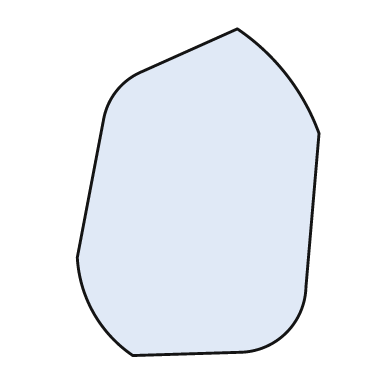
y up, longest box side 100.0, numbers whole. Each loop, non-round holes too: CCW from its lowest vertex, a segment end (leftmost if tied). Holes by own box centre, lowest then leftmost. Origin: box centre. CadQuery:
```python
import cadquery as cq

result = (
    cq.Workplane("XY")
    .moveTo(-20.0, -50.0)
    .lineTo(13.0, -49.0)
    .threePointArc((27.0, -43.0), (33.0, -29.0))
    .lineTo(37.0, 18.0)
    .threePointArc((27.0, 36.0), (12.0, 50.0))
    .lineTo(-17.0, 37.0)
    .threePointArc((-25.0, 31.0), (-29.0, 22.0))
    .lineTo(-37.0, -20.0)
    .threePointArc((-32.0, -37.0), (-20.0, -50.0))
    .close()
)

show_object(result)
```